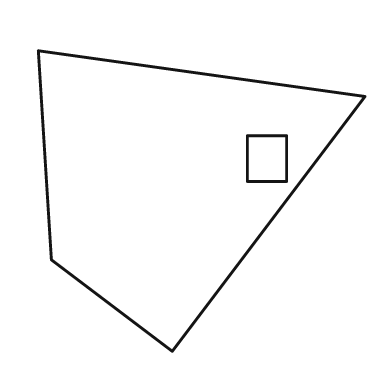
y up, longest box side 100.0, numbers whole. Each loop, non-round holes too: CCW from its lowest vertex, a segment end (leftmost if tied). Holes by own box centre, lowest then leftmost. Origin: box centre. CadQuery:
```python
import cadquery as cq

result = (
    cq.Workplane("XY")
    .moveTo(-9.0, -46.0)
    .lineTo(50.0, 32.0)
    .lineTo(-50.0, 46.0)
    .lineTo(-46.0, -18.0)
    .close()
    .moveTo(14.0, 6.0)
    .lineTo(26.0, 6.0)
    .lineTo(26.0, 20.0)
    .lineTo(14.0, 20.0)
    .close()
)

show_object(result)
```